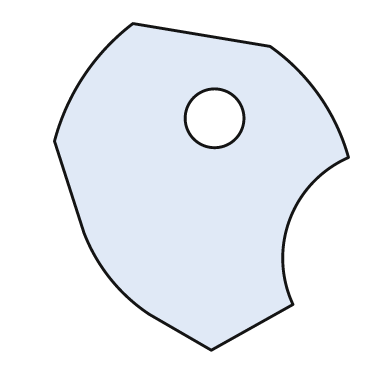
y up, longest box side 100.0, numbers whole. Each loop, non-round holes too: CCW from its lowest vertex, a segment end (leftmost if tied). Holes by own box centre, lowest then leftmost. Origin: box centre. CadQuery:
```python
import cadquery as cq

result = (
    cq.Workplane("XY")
    .moveTo(3.0, -50.0)
    .lineTo(28.0, -36.0)
    .threePointArc((27.0, -10.0), (45.0, 9.0))
    .threePointArc((36.0, 28.0), (21.0, 43.0))
    .lineTo(-21.0, 50.0)
    .threePointArc((-36.0, 34.0), (-45.0, 14.0))
    .lineTo(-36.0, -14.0)
    .threePointArc((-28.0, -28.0), (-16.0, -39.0))
    .close()
    .moveTo(4.0, 21.0)
    .circle(9.0)
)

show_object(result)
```